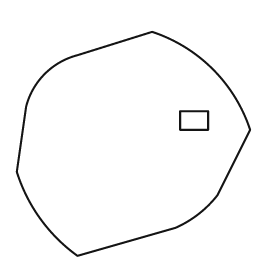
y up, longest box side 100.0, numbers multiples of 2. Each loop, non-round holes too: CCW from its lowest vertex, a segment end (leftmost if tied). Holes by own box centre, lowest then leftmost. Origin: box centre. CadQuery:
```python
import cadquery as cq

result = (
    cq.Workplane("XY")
    .moveTo(-24.0, -48.0)
    .lineTo(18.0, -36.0)
    .threePointArc((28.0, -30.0), (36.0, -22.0))
    .lineTo(50.0, 6.0)
    .threePointArc((34.0, 32.0), (8.0, 48.0))
    .lineTo(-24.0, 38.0)
    .threePointArc((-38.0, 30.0), (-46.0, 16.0))
    .lineTo(-50.0, -12.0)
    .threePointArc((-40.0, -32.0), (-24.0, -48.0))
    .close()
    .moveTo(20.0, 6.0)
    .lineTo(32.0, 6.0)
    .lineTo(32.0, 14.0)
    .lineTo(20.0, 14.0)
    .close()
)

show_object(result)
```